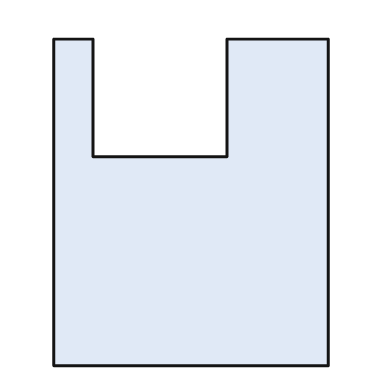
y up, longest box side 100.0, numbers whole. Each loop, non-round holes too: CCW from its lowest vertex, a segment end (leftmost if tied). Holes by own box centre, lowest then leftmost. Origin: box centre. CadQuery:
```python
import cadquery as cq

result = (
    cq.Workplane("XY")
    .moveTo(-42.0, -50.0)
    .lineTo(42.0, -50.0)
    .lineTo(42.0, 50.0)
    .lineTo(11.0, 50.0)
    .lineTo(11.0, 14.0)
    .lineTo(-30.0, 14.0)
    .lineTo(-30.0, 50.0)
    .lineTo(-42.0, 50.0)
    .close()
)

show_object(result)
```